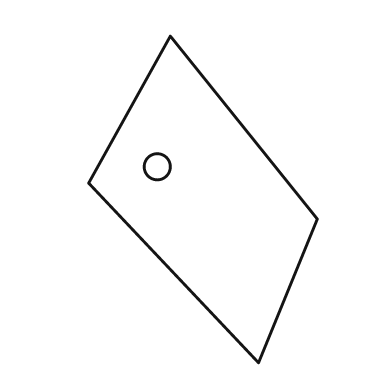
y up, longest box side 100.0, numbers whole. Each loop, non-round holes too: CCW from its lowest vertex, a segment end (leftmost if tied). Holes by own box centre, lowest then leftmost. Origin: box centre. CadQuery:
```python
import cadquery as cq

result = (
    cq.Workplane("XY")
    .moveTo(17.0, -50.0)
    .lineTo(35.0, -6.0)
    .lineTo(-10.0, 50.0)
    .lineTo(-35.0, 5.0)
    .close()
    .moveTo(-14.0, 10.0)
    .circle(4.0)
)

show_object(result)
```